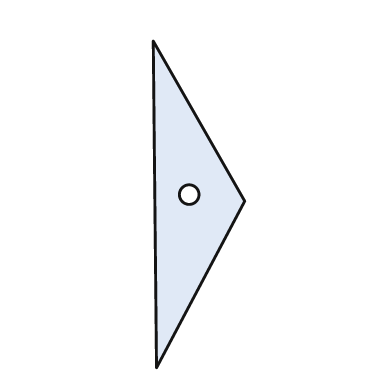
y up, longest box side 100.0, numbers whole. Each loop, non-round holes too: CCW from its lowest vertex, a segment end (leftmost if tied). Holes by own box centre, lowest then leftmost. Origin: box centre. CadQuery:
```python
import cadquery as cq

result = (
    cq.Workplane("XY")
    .moveTo(-13.0, -50.0)
    .lineTo(14.0, 1.0)
    .lineTo(-14.0, 50.0)
    .close()
    .moveTo(-3.0, 3.0)
    .circle(3.0)
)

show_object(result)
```